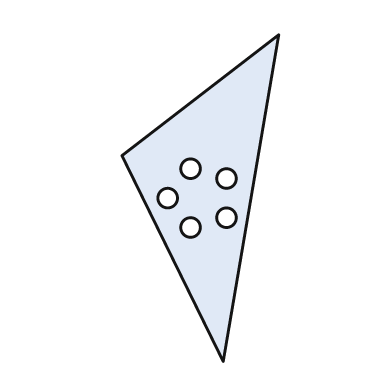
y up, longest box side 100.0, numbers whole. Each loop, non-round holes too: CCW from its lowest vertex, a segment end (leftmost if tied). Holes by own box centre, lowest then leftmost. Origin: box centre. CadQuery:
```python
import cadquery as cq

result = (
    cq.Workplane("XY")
    .moveTo(7.0, -50.0)
    .lineTo(24.0, 50.0)
    .lineTo(-24.0, 13.0)
    .close()
    .moveTo(-3.0, -9.0)
    .circle(3.0)
    .moveTo(8.0, -6.0)
    .circle(3.0)
    .moveTo(-10.0, 0.0)
    .circle(3.0)
    .moveTo(8.0, 6.0)
    .circle(3.0)
    .moveTo(-3.0, 9.0)
    .circle(3.0)
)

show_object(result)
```